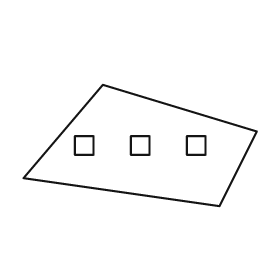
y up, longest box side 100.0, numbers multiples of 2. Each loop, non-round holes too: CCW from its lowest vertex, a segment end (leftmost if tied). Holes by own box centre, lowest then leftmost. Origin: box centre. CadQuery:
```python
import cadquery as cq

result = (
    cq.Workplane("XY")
    .moveTo(34.0, -26.0)
    .lineTo(50.0, 6.0)
    .lineTo(-16.0, 26.0)
    .lineTo(-50.0, -14.0)
    .close()
    .moveTo(-28.0, -4.0)
    .lineTo(-20.0, -4.0)
    .lineTo(-20.0, 4.0)
    .lineTo(-28.0, 4.0)
    .close()
    .moveTo(-4.0, -4.0)
    .lineTo(4.0, -4.0)
    .lineTo(4.0, 4.0)
    .lineTo(-4.0, 4.0)
    .close()
    .moveTo(20.0, -4.0)
    .lineTo(28.0, -4.0)
    .lineTo(28.0, 4.0)
    .lineTo(20.0, 4.0)
    .close()
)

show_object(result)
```